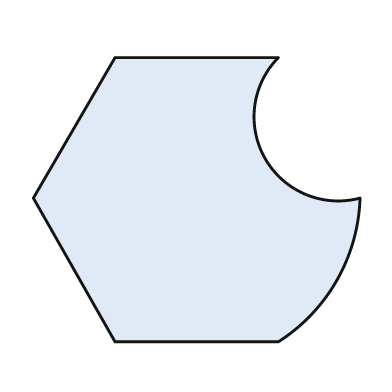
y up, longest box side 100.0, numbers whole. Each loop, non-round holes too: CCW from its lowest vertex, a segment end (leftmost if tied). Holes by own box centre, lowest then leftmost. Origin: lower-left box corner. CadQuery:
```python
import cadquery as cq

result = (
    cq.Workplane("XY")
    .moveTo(25.0, 0.0)
    .lineTo(75.0, 0.0)
    .threePointArc((93.0, 19.0), (100.0, 44.0))
    .threePointArc((71.0, 56.0), (75.0, 87.0))
    .lineTo(25.0, 87.0)
    .lineTo(0.0, 44.0)
    .close()
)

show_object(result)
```